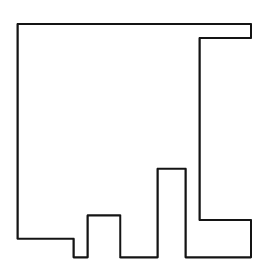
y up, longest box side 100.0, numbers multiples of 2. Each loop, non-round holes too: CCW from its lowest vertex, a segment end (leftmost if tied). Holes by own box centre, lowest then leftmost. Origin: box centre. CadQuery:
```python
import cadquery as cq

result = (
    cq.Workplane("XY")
    .moveTo(-26.0, -50.0)
    .lineTo(-20.0, -50.0)
    .lineTo(-20.0, -32.0)
    .lineTo(-6.0, -32.0)
    .lineTo(-6.0, -50.0)
    .lineTo(10.0, -50.0)
    .lineTo(10.0, -12.0)
    .lineTo(22.0, -12.0)
    .lineTo(22.0, -50.0)
    .lineTo(50.0, -50.0)
    .lineTo(50.0, -34.0)
    .lineTo(28.0, -34.0)
    .lineTo(28.0, 44.0)
    .lineTo(50.0, 44.0)
    .lineTo(50.0, 50.0)
    .lineTo(-50.0, 50.0)
    .lineTo(-50.0, -42.0)
    .lineTo(-26.0, -42.0)
    .close()
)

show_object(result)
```